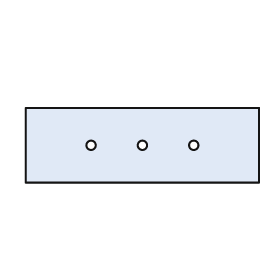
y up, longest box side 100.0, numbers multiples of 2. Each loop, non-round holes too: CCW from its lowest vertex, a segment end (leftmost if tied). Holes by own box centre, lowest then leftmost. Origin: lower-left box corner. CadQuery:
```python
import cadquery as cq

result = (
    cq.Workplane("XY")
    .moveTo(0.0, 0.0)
    .lineTo(100.0, 0.0)
    .lineTo(100.0, 32.0)
    .lineTo(0.0, 32.0)
    .close()
    .moveTo(28.0, 16.0)
    .circle(2.0)
    .moveTo(50.0, 16.0)
    .circle(2.0)
    .moveTo(72.0, 16.0)
    .circle(2.0)
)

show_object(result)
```